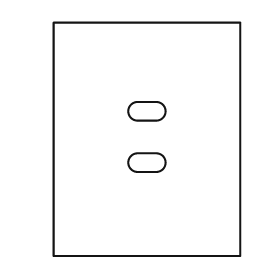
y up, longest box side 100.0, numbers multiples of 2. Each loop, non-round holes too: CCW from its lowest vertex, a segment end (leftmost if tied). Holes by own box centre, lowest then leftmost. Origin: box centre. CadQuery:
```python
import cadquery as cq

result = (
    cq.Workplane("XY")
    .moveTo(-40.0, -50.0)
    .lineTo(40.0, -50.0)
    .lineTo(40.0, 50.0)
    .lineTo(-40.0, 50.0)
    .close()
    .moveTo(-4.0, -14.0)
    .lineTo(4.0, -14.0)
    .threePointArc((8.0, -10.0), (4.0, -6.0))
    .lineTo(-4.0, -6.0)
    .threePointArc((-8.0, -10.0), (-4.0, -14.0))
    .close()
    .moveTo(-4.0, 8.0)
    .lineTo(4.0, 8.0)
    .threePointArc((8.0, 12.0), (4.0, 16.0))
    .lineTo(-4.0, 16.0)
    .threePointArc((-8.0, 12.0), (-4.0, 8.0))
    .close()
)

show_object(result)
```